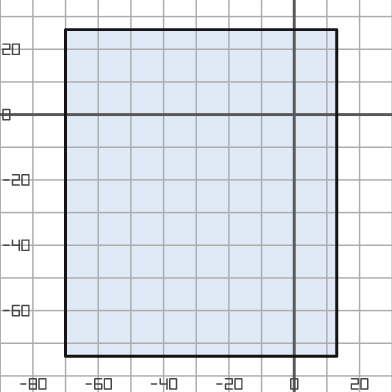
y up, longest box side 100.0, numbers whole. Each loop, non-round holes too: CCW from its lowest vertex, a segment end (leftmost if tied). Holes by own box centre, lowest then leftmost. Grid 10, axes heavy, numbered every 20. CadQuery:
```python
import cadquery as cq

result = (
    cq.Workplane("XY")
    .moveTo(-70.0, -74.0)
    .lineTo(13.0, -74.0)
    .lineTo(13.0, 26.0)
    .lineTo(-70.0, 26.0)
    .close()
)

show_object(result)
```